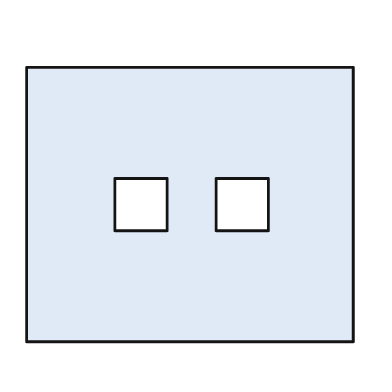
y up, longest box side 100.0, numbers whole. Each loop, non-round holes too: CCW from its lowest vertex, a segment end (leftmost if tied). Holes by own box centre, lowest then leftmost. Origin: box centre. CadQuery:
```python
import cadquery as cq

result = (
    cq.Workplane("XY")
    .moveTo(-50.0, -42.0)
    .lineTo(50.0, -42.0)
    .lineTo(50.0, 42.0)
    .lineTo(-50.0, 42.0)
    .close()
    .moveTo(-23.0, -8.0)
    .lineTo(-7.0, -8.0)
    .lineTo(-7.0, 8.0)
    .lineTo(-23.0, 8.0)
    .close()
    .moveTo(8.0, -8.0)
    .lineTo(24.0, -8.0)
    .lineTo(24.0, 8.0)
    .lineTo(8.0, 8.0)
    .close()
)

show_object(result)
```